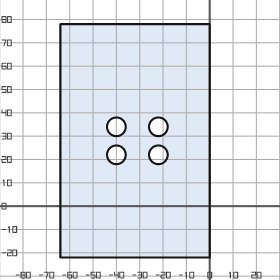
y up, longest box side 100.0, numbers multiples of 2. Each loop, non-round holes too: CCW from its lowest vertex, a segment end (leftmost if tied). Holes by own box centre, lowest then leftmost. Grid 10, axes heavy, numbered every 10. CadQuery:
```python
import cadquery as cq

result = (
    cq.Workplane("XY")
    .moveTo(-64.0, -22.0)
    .lineTo(0.0, -22.0)
    .lineTo(0.0, 78.0)
    .lineTo(-64.0, 78.0)
    .close()
    .moveTo(-40.0, 22.0)
    .circle(4.0)
    .moveTo(-22.0, 22.0)
    .circle(4.0)
    .moveTo(-40.0, 34.0)
    .circle(4.0)
    .moveTo(-22.0, 34.0)
    .circle(4.0)
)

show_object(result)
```